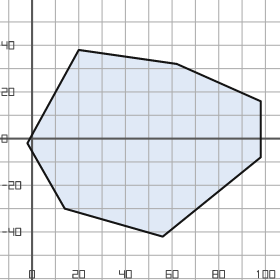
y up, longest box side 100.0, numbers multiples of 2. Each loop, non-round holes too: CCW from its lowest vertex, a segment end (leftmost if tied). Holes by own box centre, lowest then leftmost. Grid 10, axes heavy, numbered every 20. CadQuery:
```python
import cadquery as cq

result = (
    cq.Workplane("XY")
    .moveTo(56.0, -42.0)
    .lineTo(98.0, -8.0)
    .lineTo(98.0, 16.0)
    .lineTo(62.0, 32.0)
    .lineTo(20.0, 38.0)
    .lineTo(-2.0, -2.0)
    .lineTo(14.0, -30.0)
    .close()
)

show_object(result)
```